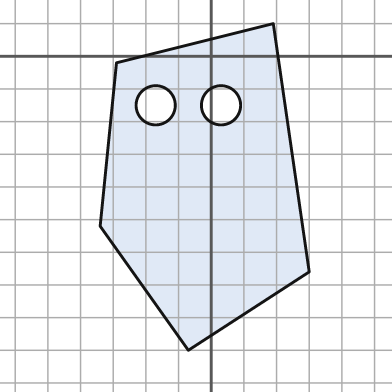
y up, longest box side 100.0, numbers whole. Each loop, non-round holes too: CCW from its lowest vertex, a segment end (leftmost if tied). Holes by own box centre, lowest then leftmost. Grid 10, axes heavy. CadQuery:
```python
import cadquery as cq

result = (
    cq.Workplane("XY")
    .moveTo(-7.0, -90.0)
    .lineTo(30.0, -66.0)
    .lineTo(19.0, 10.0)
    .lineTo(-29.0, -2.0)
    .lineTo(-34.0, -52.0)
    .close()
    .moveTo(-17.0, -15.0)
    .circle(6.0)
    .moveTo(3.0, -15.0)
    .circle(6.0)
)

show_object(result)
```